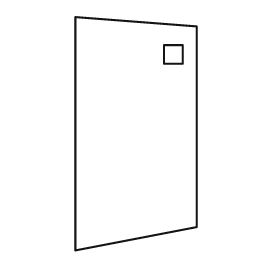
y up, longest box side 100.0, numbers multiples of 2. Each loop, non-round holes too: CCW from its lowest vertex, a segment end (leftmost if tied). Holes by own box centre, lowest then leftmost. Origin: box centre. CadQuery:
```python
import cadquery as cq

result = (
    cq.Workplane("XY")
    .moveTo(-26.0, -50.0)
    .lineTo(26.0, -40.0)
    .lineTo(26.0, 46.0)
    .lineTo(-26.0, 50.0)
    .close()
    .moveTo(12.0, 30.0)
    .lineTo(20.0, 30.0)
    .lineTo(20.0, 38.0)
    .lineTo(12.0, 38.0)
    .close()
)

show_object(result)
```